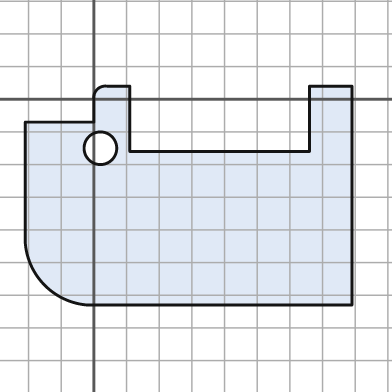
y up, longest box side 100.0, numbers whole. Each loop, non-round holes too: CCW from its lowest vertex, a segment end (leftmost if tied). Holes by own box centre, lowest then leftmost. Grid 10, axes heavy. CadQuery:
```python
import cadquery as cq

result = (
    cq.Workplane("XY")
    .moveTo(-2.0, -63.0)
    .lineTo(79.0, -63.0)
    .lineTo(79.0, 4.0)
    .lineTo(66.0, 4.0)
    .lineTo(66.0, -16.0)
    .lineTo(11.0, -16.0)
    .lineTo(11.0, 4.0)
    .lineTo(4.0, 4.0)
    .threePointArc((1.0, 3.0), (0.0, 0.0))
    .lineTo(0.0, -7.0)
    .lineTo(-21.0, -7.0)
    .lineTo(-21.0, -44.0)
    .threePointArc((-15.0, -57.0), (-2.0, -63.0))
    .close()
    .moveTo(2.0, -15.0)
    .circle(5.0)
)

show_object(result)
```